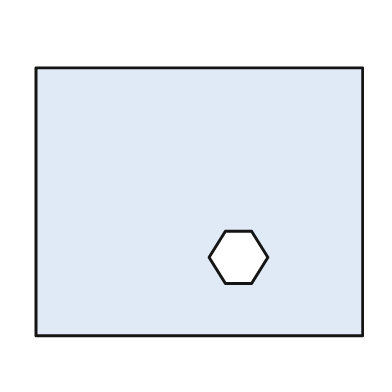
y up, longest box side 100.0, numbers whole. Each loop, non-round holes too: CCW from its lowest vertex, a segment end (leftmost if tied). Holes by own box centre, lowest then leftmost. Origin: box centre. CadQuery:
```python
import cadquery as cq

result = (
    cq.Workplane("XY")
    .moveTo(-50.0, -41.0)
    .lineTo(50.0, -41.0)
    .lineTo(50.0, 41.0)
    .lineTo(-50.0, 41.0)
    .close()
    .moveTo(8.0, -25.0)
    .lineTo(16.0, -25.0)
    .lineTo(21.0, -17.0)
    .lineTo(16.0, -9.0)
    .lineTo(8.0, -9.0)
    .lineTo(3.0, -17.0)
    .close()
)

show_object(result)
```